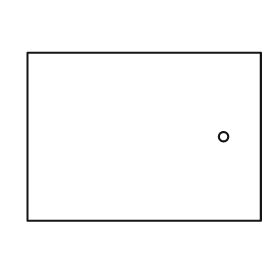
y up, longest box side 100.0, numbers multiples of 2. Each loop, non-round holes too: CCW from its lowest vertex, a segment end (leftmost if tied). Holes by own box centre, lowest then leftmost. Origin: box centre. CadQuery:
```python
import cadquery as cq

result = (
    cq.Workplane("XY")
    .moveTo(-50.0, -36.0)
    .lineTo(50.0, -36.0)
    .lineTo(50.0, 36.0)
    .lineTo(-50.0, 36.0)
    .close()
    .moveTo(34.0, 0.0)
    .circle(2.0)
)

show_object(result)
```